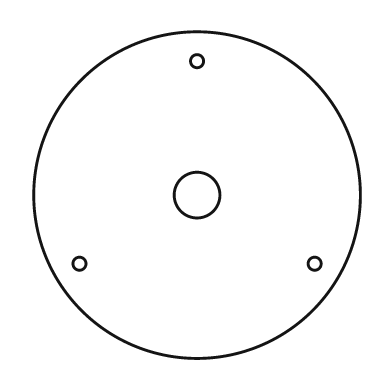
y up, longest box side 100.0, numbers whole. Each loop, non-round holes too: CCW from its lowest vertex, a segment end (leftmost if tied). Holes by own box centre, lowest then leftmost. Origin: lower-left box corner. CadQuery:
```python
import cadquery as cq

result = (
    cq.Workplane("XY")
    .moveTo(50.0, 50.0)
    .circle(50.0)
    .moveTo(14.0, 29.0)
    .circle(2.0)
    .moveTo(86.0, 29.0)
    .circle(2.0)
    .moveTo(50.0, 50.0)
    .circle(7.0)
    .moveTo(50.0, 91.0)
    .circle(2.0)
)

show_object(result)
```